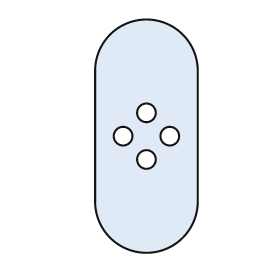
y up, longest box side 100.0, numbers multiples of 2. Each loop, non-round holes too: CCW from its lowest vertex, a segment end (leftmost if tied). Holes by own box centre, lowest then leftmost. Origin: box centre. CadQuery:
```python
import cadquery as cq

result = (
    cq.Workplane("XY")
    .moveTo(-22.0, -28.0)
    .threePointArc((0.0, -50.0), (22.0, -28.0))
    .lineTo(22.0, 28.0)
    .threePointArc((0.0, 50.0), (-22.0, 28.0))
    .close()
    .moveTo(0.0, -10.0)
    .circle(4.0)
    .moveTo(-10.0, 0.0)
    .circle(4.0)
    .moveTo(10.0, 0.0)
    .circle(4.0)
    .moveTo(0.0, 10.0)
    .circle(4.0)
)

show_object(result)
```